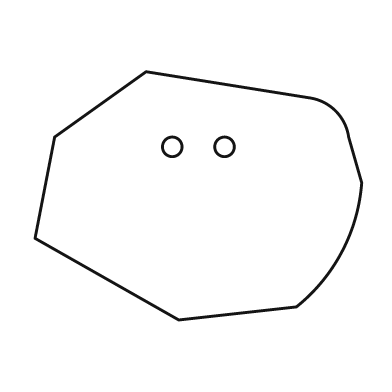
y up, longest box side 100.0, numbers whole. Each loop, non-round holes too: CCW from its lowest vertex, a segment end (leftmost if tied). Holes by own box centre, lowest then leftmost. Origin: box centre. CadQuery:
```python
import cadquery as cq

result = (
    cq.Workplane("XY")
    .moveTo(-6.0, -38.0)
    .lineTo(30.0, -34.0)
    .threePointArc((44.0, -17.0), (50.0, 4.0))
    .lineTo(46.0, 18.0)
    .threePointArc((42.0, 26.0), (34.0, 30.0))
    .lineTo(-16.0, 38.0)
    .lineTo(-44.0, 18.0)
    .lineTo(-50.0, -13.0)
    .close()
    .moveTo(-8.0, 15.0)
    .circle(3.0)
    .moveTo(8.0, 15.0)
    .circle(3.0)
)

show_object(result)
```